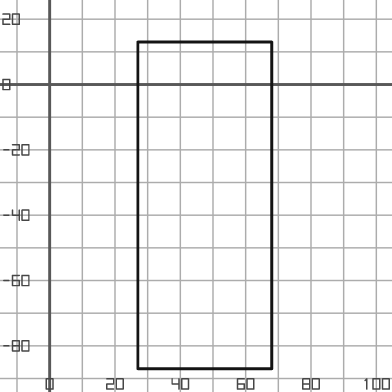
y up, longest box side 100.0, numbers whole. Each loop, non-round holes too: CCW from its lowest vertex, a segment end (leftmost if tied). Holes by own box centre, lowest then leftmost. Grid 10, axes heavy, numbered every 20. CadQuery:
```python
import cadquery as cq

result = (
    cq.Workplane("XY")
    .moveTo(27.0, -87.0)
    .lineTo(68.0, -87.0)
    .lineTo(68.0, 13.0)
    .lineTo(27.0, 13.0)
    .close()
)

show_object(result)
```